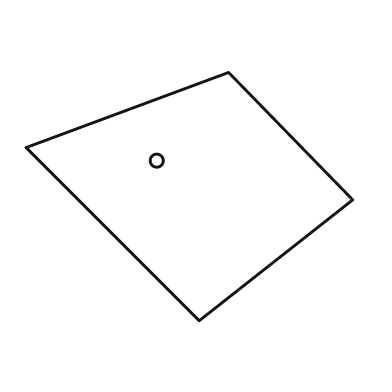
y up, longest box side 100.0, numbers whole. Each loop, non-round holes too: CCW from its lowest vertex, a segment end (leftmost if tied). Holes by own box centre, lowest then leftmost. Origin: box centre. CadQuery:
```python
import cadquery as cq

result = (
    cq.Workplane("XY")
    .moveTo(3.0, -38.0)
    .lineTo(50.0, -1.0)
    .lineTo(12.0, 38.0)
    .lineTo(-50.0, 15.0)
    .close()
    .moveTo(-10.0, 11.0)
    .circle(2.0)
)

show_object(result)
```